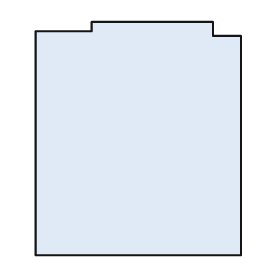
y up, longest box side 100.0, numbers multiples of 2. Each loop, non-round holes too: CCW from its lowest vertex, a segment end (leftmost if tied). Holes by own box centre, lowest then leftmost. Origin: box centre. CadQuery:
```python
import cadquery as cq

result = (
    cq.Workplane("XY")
    .moveTo(-44.0, -50.0)
    .lineTo(44.0, -50.0)
    .lineTo(44.0, 44.0)
    .lineTo(32.0, 44.0)
    .lineTo(32.0, 50.0)
    .lineTo(-20.0, 50.0)
    .lineTo(-20.0, 46.0)
    .lineTo(-44.0, 46.0)
    .close()
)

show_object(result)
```